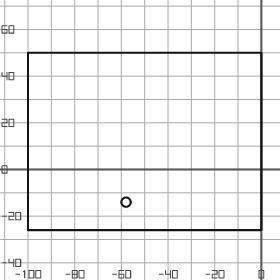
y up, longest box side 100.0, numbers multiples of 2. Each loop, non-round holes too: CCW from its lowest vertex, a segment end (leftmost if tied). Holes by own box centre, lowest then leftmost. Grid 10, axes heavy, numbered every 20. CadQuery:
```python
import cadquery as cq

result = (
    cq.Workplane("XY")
    .moveTo(-100.0, -26.0)
    .lineTo(0.0, -26.0)
    .lineTo(0.0, 50.0)
    .lineTo(-100.0, 50.0)
    .close()
    .moveTo(-58.0, -14.0)
    .circle(2.0)
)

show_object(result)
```